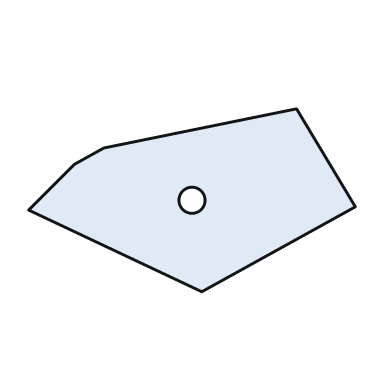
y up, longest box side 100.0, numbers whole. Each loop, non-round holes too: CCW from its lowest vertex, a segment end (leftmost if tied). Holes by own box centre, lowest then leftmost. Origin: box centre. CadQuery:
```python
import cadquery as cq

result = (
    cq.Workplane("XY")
    .moveTo(3.0, -28.0)
    .lineTo(50.0, -2.0)
    .lineTo(32.0, 28.0)
    .lineTo(-27.0, 16.0)
    .lineTo(-36.0, 11.0)
    .lineTo(-50.0, -3.0)
    .close()
    .moveTo(0.0, 0.0)
    .circle(4.0)
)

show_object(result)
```